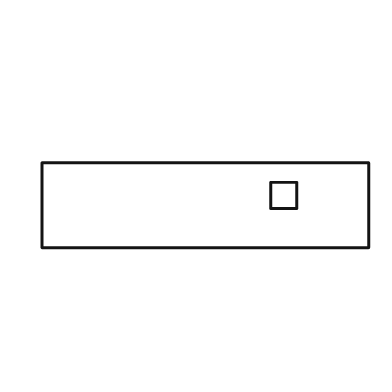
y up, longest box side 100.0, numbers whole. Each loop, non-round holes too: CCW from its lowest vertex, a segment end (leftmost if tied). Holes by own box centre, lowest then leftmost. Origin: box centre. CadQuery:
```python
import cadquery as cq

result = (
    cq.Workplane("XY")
    .moveTo(-50.0, -13.0)
    .lineTo(50.0, -13.0)
    .lineTo(50.0, 13.0)
    .lineTo(-50.0, 13.0)
    .close()
    .moveTo(20.0, -1.0)
    .lineTo(28.0, -1.0)
    .lineTo(28.0, 7.0)
    .lineTo(20.0, 7.0)
    .close()
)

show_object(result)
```